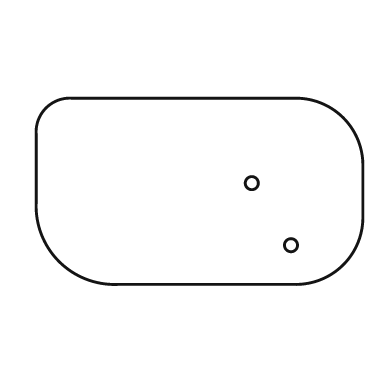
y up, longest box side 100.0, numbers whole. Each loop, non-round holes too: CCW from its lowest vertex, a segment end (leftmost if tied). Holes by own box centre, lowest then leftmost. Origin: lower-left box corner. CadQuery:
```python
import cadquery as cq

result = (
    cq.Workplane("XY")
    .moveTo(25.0, 0.0)
    .lineTo(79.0, 0.0)
    .threePointArc((94.0, 6.0), (100.0, 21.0))
    .lineTo(100.0, 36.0)
    .threePointArc((94.0, 51.0), (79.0, 57.0))
    .lineTo(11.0, 57.0)
    .threePointArc((3.0, 54.0), (0.0, 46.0))
    .lineTo(0.0, 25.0)
    .threePointArc((7.0, 7.0), (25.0, 0.0))
    .close()
    .moveTo(78.0, 12.0)
    .circle(2.0)
    .moveTo(66.0, 31.0)
    .circle(2.0)
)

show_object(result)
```